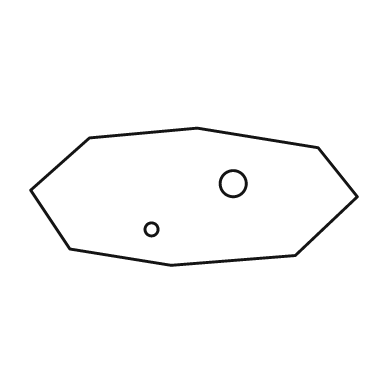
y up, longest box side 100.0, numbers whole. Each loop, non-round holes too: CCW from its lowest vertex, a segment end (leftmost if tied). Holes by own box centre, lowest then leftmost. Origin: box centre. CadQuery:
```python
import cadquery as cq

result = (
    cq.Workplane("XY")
    .moveTo(-7.0, -21.0)
    .lineTo(31.0, -18.0)
    .lineTo(50.0, 0.0)
    .lineTo(38.0, 15.0)
    .lineTo(1.0, 21.0)
    .lineTo(-32.0, 18.0)
    .lineTo(-50.0, 2.0)
    .lineTo(-38.0, -16.0)
    .close()
    .moveTo(-13.0, -10.0)
    .circle(2.0)
    .moveTo(12.0, 4.0)
    .circle(4.0)
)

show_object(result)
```